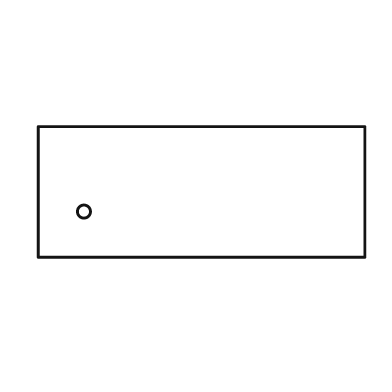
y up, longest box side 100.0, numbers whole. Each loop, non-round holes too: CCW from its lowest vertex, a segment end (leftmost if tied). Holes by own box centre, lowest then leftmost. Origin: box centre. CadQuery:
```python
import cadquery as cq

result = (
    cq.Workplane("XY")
    .moveTo(-50.0, -20.0)
    .lineTo(50.0, -20.0)
    .lineTo(50.0, 20.0)
    .lineTo(-50.0, 20.0)
    .close()
    .moveTo(-36.0, -6.0)
    .circle(2.0)
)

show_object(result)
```